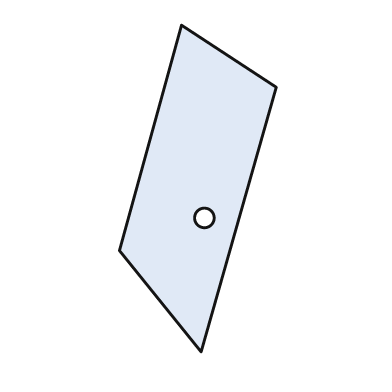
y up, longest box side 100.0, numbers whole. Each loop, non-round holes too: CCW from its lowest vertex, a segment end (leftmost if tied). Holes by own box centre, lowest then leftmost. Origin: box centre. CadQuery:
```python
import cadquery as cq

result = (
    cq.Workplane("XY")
    .moveTo(1.0, -50.0)
    .lineTo(24.0, 31.0)
    .lineTo(-5.0, 50.0)
    .lineTo(-24.0, -19.0)
    .close()
    .moveTo(2.0, -9.0)
    .circle(3.0)
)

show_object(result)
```